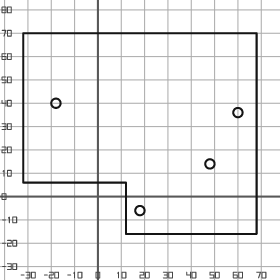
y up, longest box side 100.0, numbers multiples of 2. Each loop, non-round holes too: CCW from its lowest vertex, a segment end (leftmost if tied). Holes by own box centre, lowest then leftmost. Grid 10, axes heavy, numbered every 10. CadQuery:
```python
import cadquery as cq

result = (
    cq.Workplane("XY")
    .moveTo(12.0, -16.0)
    .lineTo(68.0, -16.0)
    .lineTo(68.0, 70.0)
    .lineTo(-32.0, 70.0)
    .lineTo(-32.0, 6.0)
    .lineTo(12.0, 6.0)
    .close()
    .moveTo(18.0, -6.0)
    .circle(2.0)
    .moveTo(48.0, 14.0)
    .circle(2.0)
    .moveTo(60.0, 36.0)
    .circle(2.0)
    .moveTo(-18.0, 40.0)
    .circle(2.0)
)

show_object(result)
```